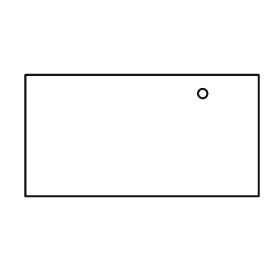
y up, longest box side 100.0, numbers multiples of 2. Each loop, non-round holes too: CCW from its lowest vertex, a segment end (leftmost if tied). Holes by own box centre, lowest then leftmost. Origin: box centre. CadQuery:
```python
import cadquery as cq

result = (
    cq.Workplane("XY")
    .moveTo(-50.0, -26.0)
    .lineTo(50.0, -26.0)
    .lineTo(50.0, 26.0)
    .lineTo(-50.0, 26.0)
    .close()
    .moveTo(26.0, 18.0)
    .circle(2.0)
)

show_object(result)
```